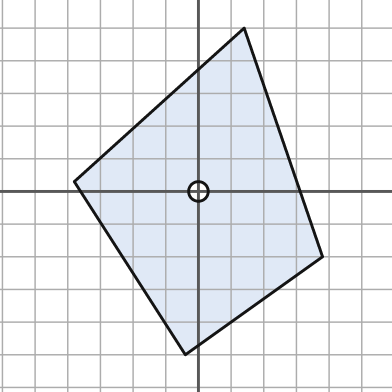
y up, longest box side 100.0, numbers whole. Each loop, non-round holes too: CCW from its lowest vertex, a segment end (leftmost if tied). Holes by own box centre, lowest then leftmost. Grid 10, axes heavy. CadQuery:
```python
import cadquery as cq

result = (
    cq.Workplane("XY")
    .moveTo(-4.0, -50.0)
    .lineTo(38.0, -20.0)
    .lineTo(14.0, 50.0)
    .lineTo(-38.0, 3.0)
    .close()
    .moveTo(0.0, 0.0)
    .circle(3.0)
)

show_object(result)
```